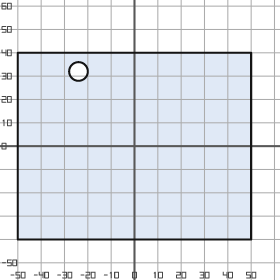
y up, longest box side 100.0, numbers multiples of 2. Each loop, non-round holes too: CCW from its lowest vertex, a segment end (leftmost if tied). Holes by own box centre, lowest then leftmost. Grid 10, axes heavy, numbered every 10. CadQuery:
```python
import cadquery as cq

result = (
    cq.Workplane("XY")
    .moveTo(-50.0, -40.0)
    .lineTo(50.0, -40.0)
    .lineTo(50.0, 40.0)
    .lineTo(-50.0, 40.0)
    .close()
    .moveTo(-24.0, 32.0)
    .circle(4.0)
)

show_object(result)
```